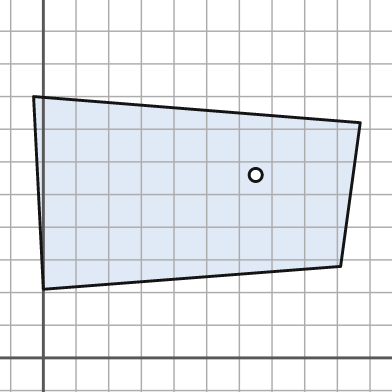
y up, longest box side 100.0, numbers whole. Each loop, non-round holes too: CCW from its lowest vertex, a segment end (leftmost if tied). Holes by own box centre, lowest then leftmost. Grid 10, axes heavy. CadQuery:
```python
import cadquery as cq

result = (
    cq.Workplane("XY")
    .moveTo(0.0, 21.0)
    .lineTo(91.0, 28.0)
    .lineTo(97.0, 72.0)
    .lineTo(-3.0, 80.0)
    .close()
    .moveTo(65.0, 56.0)
    .circle(2.0)
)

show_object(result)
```